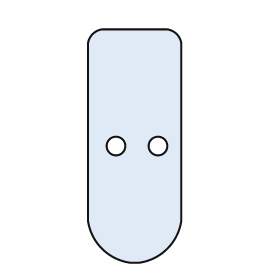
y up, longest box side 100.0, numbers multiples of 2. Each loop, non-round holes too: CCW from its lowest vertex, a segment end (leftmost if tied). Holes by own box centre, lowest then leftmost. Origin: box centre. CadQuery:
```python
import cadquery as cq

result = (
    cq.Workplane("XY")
    .moveTo(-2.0, -50.0)
    .lineTo(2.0, -50.0)
    .threePointArc((14.0, -44.0), (20.0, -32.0))
    .lineTo(20.0, 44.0)
    .threePointArc((18.0, 48.0), (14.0, 50.0))
    .lineTo(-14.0, 50.0)
    .threePointArc((-18.0, 48.0), (-20.0, 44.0))
    .lineTo(-20.0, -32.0)
    .threePointArc((-14.0, -44.0), (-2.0, -50.0))
    .close()
    .moveTo(-8.0, 0.0)
    .circle(4.0)
    .moveTo(10.0, 0.0)
    .circle(4.0)
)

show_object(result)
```